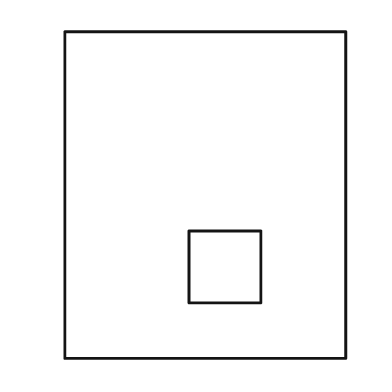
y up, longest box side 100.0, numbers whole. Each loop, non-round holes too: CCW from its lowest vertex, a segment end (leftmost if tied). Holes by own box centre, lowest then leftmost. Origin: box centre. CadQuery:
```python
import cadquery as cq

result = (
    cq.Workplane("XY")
    .moveTo(-43.0, -50.0)
    .lineTo(43.0, -50.0)
    .lineTo(43.0, 50.0)
    .lineTo(-43.0, 50.0)
    .close()
    .moveTo(-5.0, -33.0)
    .lineTo(17.0, -33.0)
    .lineTo(17.0, -11.0)
    .lineTo(-5.0, -11.0)
    .close()
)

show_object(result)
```